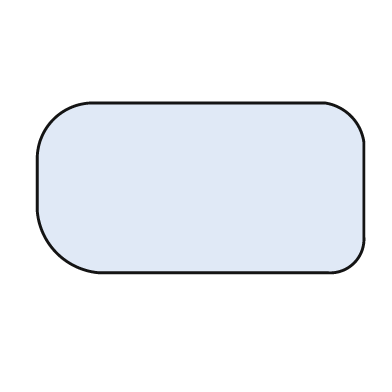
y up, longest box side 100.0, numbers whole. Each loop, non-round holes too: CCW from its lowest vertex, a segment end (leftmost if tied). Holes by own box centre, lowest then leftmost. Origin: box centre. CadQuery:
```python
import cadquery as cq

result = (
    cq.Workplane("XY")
    .moveTo(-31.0, -26.0)
    .lineTo(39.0, -26.0)
    .threePointArc((47.0, -23.0), (50.0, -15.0))
    .lineTo(50.0, 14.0)
    .threePointArc((46.0, 22.0), (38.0, 26.0))
    .lineTo(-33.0, 26.0)
    .threePointArc((-45.0, 21.0), (-50.0, 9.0))
    .lineTo(-50.0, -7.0)
    .threePointArc((-44.0, -20.0), (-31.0, -26.0))
    .close()
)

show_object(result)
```